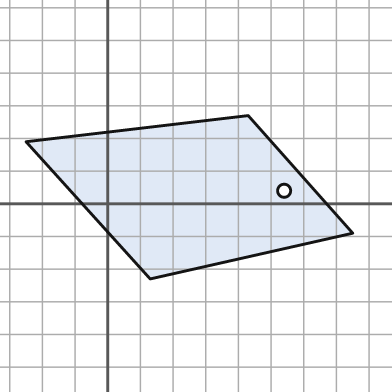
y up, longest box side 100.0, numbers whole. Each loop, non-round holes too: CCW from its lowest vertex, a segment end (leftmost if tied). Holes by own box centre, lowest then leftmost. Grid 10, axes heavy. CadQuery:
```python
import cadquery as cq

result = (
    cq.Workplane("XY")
    .moveTo(13.0, -23.0)
    .lineTo(75.0, -9.0)
    .lineTo(43.0, 27.0)
    .lineTo(-25.0, 19.0)
    .close()
    .moveTo(54.0, 4.0)
    .circle(2.0)
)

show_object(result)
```